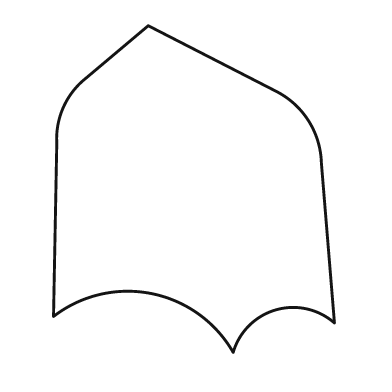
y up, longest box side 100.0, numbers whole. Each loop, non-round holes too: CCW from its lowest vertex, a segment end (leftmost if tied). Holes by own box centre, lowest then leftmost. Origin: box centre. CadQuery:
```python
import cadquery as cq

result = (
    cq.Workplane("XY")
    .moveTo(12.0, -50.0)
    .threePointArc((25.0, -37.0), (43.0, -41.0))
    .lineTo(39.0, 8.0)
    .threePointArc((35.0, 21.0), (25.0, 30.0))
    .lineTo(-14.0, 50.0)
    .lineTo(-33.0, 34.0)
    .threePointArc((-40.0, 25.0), (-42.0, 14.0))
    .lineTo(-43.0, -39.0)
    .threePointArc((-13.0, -32.0), (12.0, -50.0))
    .close()
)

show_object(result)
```